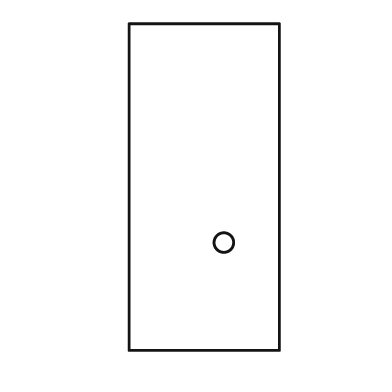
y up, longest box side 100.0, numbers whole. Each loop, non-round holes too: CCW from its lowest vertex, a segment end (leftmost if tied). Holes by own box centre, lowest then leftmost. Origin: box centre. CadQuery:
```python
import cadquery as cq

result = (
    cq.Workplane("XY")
    .moveTo(-23.0, -50.0)
    .lineTo(23.0, -50.0)
    .lineTo(23.0, 50.0)
    .lineTo(-23.0, 50.0)
    .close()
    .moveTo(6.0, -17.0)
    .circle(3.0)
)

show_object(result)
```